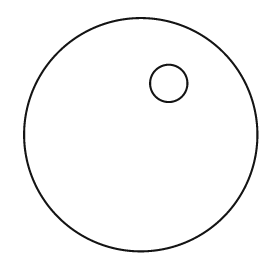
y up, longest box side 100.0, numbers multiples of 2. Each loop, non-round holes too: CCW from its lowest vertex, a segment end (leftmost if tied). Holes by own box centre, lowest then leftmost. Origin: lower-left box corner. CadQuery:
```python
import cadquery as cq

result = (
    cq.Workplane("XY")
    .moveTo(50.0, 50.0)
    .circle(50.0)
    .moveTo(62.0, 72.0)
    .circle(8.0)
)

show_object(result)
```